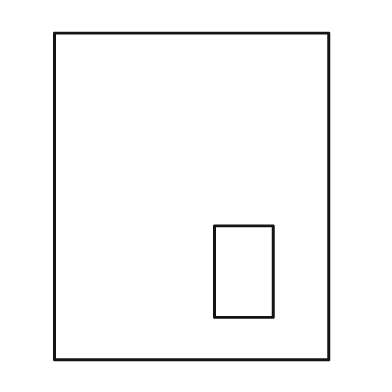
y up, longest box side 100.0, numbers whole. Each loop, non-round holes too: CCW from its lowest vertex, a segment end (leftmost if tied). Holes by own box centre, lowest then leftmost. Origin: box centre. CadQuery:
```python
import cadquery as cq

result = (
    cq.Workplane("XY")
    .moveTo(-42.0, -50.0)
    .lineTo(42.0, -50.0)
    .lineTo(42.0, 50.0)
    .lineTo(-42.0, 50.0)
    .close()
    .moveTo(7.0, -37.0)
    .lineTo(25.0, -37.0)
    .lineTo(25.0, -9.0)
    .lineTo(7.0, -9.0)
    .close()
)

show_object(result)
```